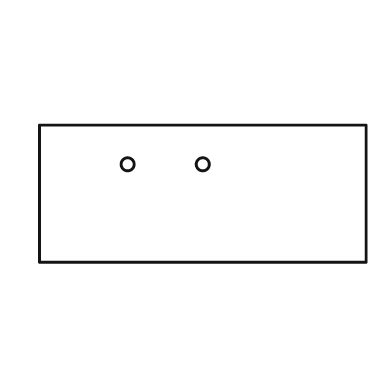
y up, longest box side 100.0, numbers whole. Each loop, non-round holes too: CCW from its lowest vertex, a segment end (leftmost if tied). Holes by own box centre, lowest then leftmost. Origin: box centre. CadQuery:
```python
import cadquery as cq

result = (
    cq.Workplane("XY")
    .moveTo(-50.0, -21.0)
    .lineTo(50.0, -21.0)
    .lineTo(50.0, 21.0)
    .lineTo(-50.0, 21.0)
    .close()
    .moveTo(-23.0, 9.0)
    .circle(2.0)
    .moveTo(0.0, 9.0)
    .circle(2.0)
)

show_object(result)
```